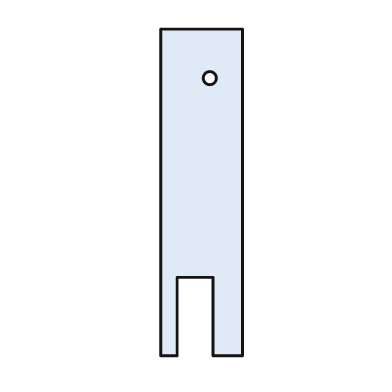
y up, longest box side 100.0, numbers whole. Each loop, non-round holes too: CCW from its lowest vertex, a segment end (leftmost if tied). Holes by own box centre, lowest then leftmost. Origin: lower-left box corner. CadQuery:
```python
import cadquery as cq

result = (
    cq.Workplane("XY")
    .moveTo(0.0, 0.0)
    .lineTo(5.0, 0.0)
    .lineTo(5.0, 24.0)
    .lineTo(16.0, 24.0)
    .lineTo(16.0, 0.0)
    .lineTo(25.0, 0.0)
    .lineTo(25.0, 100.0)
    .lineTo(0.0, 100.0)
    .close()
    .moveTo(15.0, 85.0)
    .circle(2.0)
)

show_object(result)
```